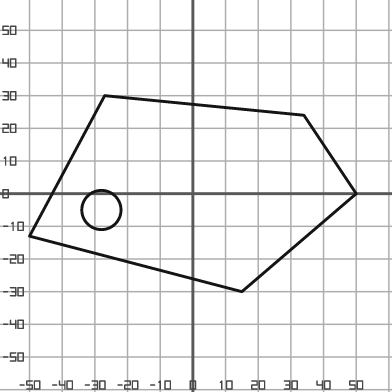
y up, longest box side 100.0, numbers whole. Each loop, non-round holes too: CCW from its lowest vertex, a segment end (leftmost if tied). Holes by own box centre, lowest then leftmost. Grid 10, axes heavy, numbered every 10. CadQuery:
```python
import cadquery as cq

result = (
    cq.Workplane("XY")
    .moveTo(15.0, -30.0)
    .lineTo(50.0, 0.0)
    .lineTo(34.0, 24.0)
    .lineTo(-27.0, 30.0)
    .lineTo(-50.0, -13.0)
    .close()
    .moveTo(-28.0, -5.0)
    .circle(6.0)
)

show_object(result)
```